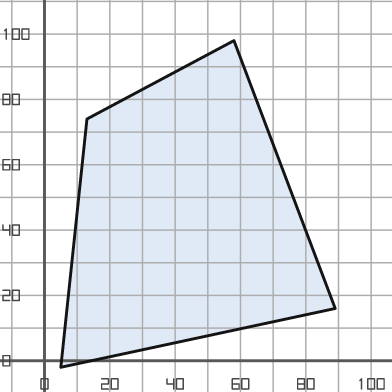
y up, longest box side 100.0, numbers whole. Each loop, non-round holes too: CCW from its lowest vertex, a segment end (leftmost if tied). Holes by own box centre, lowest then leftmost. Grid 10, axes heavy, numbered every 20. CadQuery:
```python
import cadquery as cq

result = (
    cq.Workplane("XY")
    .moveTo(5.0, -2.0)
    .lineTo(89.0, 16.0)
    .lineTo(58.0, 98.0)
    .lineTo(13.0, 74.0)
    .close()
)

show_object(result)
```